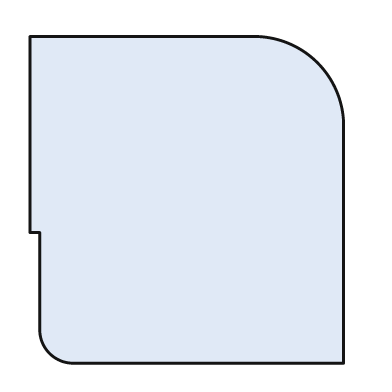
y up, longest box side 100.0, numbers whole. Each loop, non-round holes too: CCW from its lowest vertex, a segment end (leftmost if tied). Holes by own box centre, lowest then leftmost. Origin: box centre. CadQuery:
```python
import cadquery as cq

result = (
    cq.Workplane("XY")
    .moveTo(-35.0, -50.0)
    .lineTo(48.0, -50.0)
    .lineTo(48.0, 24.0)
    .threePointArc((40.0, 42.0), (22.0, 50.0))
    .lineTo(-48.0, 50.0)
    .lineTo(-48.0, -10.0)
    .lineTo(-45.0, -10.0)
    .lineTo(-45.0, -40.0)
    .threePointArc((-42.0, -47.0), (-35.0, -50.0))
    .close()
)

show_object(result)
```